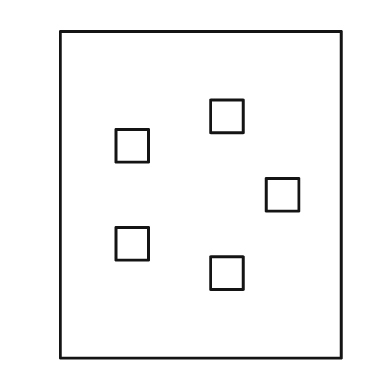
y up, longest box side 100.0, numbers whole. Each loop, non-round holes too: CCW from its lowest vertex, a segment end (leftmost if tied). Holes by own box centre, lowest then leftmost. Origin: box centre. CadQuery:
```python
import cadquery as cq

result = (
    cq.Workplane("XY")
    .moveTo(-43.0, -50.0)
    .lineTo(43.0, -50.0)
    .lineTo(43.0, 50.0)
    .lineTo(-43.0, 50.0)
    .close()
    .moveTo(3.0, -29.0)
    .lineTo(13.0, -29.0)
    .lineTo(13.0, -19.0)
    .lineTo(3.0, -19.0)
    .close()
    .moveTo(-26.0, -20.0)
    .lineTo(-16.0, -20.0)
    .lineTo(-16.0, -10.0)
    .lineTo(-26.0, -10.0)
    .close()
    .moveTo(20.0, -5.0)
    .lineTo(30.0, -5.0)
    .lineTo(30.0, 5.0)
    .lineTo(20.0, 5.0)
    .close()
    .moveTo(-26.0, 10.0)
    .lineTo(-16.0, 10.0)
    .lineTo(-16.0, 20.0)
    .lineTo(-26.0, 20.0)
    .close()
    .moveTo(3.0, 19.0)
    .lineTo(13.0, 19.0)
    .lineTo(13.0, 29.0)
    .lineTo(3.0, 29.0)
    .close()
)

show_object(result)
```